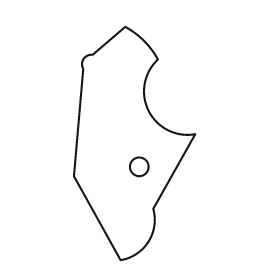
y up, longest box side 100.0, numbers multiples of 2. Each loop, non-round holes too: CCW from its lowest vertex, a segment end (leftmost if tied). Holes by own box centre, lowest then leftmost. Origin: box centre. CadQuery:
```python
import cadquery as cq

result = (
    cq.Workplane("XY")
    .moveTo(-6.0, -50.0)
    .threePointArc((6.0, -42.0), (8.0, -28.0))
    .lineTo(26.0, 4.0)
    .threePointArc((6.0, 14.0), (10.0, 36.0))
    .threePointArc((4.0, 44.0), (-4.0, 50.0))
    .lineTo(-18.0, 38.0)
    .threePointArc((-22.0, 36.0), (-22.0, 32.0))
    .lineTo(-26.0, -14.0)
    .close()
    .moveTo(2.0, -10.0)
    .circle(4.0)
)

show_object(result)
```